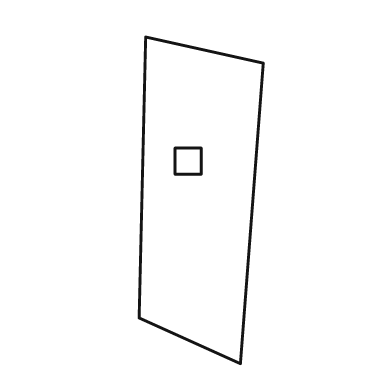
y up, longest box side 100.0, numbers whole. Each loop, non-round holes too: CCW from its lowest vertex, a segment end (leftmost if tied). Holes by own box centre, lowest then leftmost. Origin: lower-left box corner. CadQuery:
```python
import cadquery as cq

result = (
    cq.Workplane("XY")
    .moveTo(31.0, 0.0)
    .lineTo(38.0, 92.0)
    .lineTo(2.0, 100.0)
    .lineTo(0.0, 14.0)
    .close()
    .moveTo(11.0, 58.0)
    .lineTo(19.0, 58.0)
    .lineTo(19.0, 66.0)
    .lineTo(11.0, 66.0)
    .close()
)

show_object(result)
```